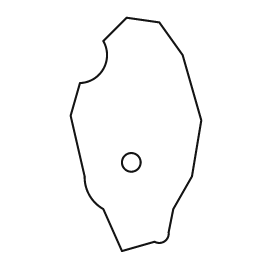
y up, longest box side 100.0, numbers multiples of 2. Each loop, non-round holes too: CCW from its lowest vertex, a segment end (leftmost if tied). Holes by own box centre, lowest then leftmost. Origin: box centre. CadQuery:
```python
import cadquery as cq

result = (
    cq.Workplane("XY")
    .moveTo(-6.0, -50.0)
    .lineTo(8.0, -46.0)
    .threePointArc((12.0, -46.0), (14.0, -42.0))
    .lineTo(16.0, -32.0)
    .lineTo(24.0, -18.0)
    .lineTo(28.0, 6.0)
    .lineTo(20.0, 34.0)
    .lineTo(10.0, 48.0)
    .lineTo(-4.0, 50.0)
    .lineTo(-14.0, 40.0)
    .threePointArc((-14.0, 28.0), (-24.0, 22.0))
    .lineTo(-28.0, 8.0)
    .lineTo(-22.0, -18.0)
    .threePointArc((-20.0, -26.0), (-14.0, -32.0))
    .close()
    .moveTo(-2.0, -12.0)
    .circle(4.0)
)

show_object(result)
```